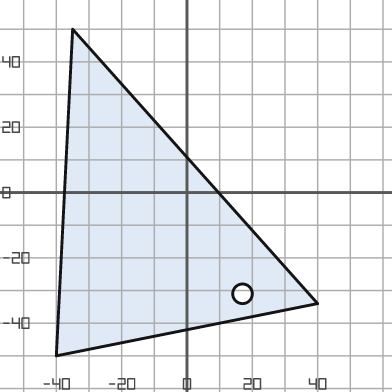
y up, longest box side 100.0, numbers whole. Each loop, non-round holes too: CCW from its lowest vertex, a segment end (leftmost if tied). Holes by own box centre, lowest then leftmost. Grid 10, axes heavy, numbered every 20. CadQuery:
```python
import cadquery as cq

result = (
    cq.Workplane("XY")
    .moveTo(-40.0, -50.0)
    .lineTo(40.0, -34.0)
    .lineTo(-35.0, 50.0)
    .close()
    .moveTo(17.0, -31.0)
    .circle(3.0)
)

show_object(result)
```